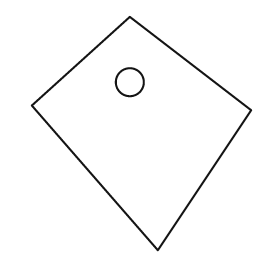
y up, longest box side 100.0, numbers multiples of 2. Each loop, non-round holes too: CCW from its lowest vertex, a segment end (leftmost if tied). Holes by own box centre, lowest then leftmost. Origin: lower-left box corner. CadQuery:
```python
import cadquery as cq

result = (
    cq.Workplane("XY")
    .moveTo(54.0, 0.0)
    .lineTo(94.0, 60.0)
    .lineTo(42.0, 100.0)
    .lineTo(0.0, 62.0)
    .close()
    .moveTo(42.0, 72.0)
    .circle(6.0)
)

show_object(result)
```